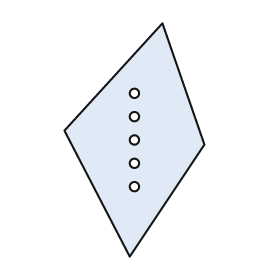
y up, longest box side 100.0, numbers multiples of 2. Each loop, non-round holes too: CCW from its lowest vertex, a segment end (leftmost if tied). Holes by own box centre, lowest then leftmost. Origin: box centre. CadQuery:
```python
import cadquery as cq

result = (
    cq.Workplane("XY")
    .moveTo(-2.0, -50.0)
    .lineTo(30.0, -2.0)
    .lineTo(12.0, 50.0)
    .lineTo(-30.0, 4.0)
    .close()
    .moveTo(0.0, -20.0)
    .circle(2.0)
    .moveTo(0.0, -10.0)
    .circle(2.0)
    .moveTo(0.0, 0.0)
    .circle(2.0)
    .moveTo(0.0, 10.0)
    .circle(2.0)
    .moveTo(0.0, 20.0)
    .circle(2.0)
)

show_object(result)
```